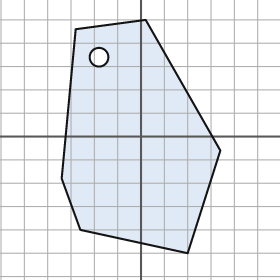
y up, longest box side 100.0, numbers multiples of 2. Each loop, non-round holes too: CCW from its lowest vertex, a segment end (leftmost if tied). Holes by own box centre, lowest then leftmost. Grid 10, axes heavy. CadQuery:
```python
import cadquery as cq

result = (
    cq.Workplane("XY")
    .moveTo(20.0, -50.0)
    .lineTo(34.0, -6.0)
    .lineTo(2.0, 50.0)
    .lineTo(-28.0, 46.0)
    .lineTo(-34.0, -18.0)
    .lineTo(-26.0, -40.0)
    .close()
    .moveTo(-18.0, 34.0)
    .circle(4.0)
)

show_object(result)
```